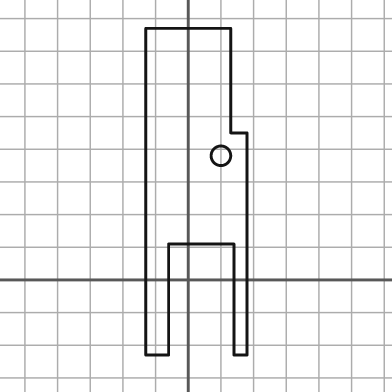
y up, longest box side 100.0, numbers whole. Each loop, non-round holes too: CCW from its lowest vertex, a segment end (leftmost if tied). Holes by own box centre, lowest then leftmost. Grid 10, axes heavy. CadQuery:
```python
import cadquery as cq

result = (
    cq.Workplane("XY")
    .moveTo(-13.0, -23.0)
    .lineTo(-6.0, -23.0)
    .lineTo(-6.0, 11.0)
    .lineTo(14.0, 11.0)
    .lineTo(14.0, -23.0)
    .lineTo(18.0, -23.0)
    .lineTo(18.0, 45.0)
    .lineTo(13.0, 45.0)
    .lineTo(13.0, 77.0)
    .lineTo(-13.0, 77.0)
    .close()
    .moveTo(10.0, 38.0)
    .circle(3.0)
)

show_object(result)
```